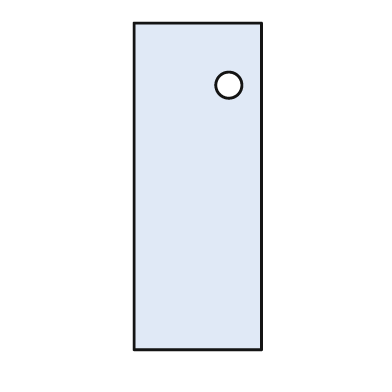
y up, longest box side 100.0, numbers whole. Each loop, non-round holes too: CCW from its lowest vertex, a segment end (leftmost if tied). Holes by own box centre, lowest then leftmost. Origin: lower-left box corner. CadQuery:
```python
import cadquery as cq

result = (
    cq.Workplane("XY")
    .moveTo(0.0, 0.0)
    .lineTo(39.0, 0.0)
    .lineTo(39.0, 100.0)
    .lineTo(0.0, 100.0)
    .close()
    .moveTo(29.0, 81.0)
    .circle(4.0)
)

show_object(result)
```